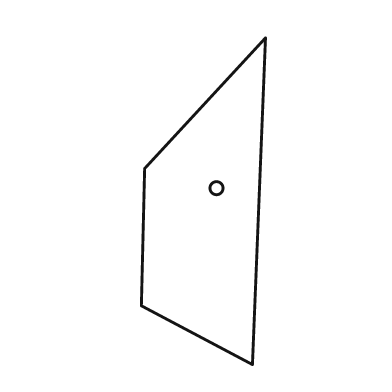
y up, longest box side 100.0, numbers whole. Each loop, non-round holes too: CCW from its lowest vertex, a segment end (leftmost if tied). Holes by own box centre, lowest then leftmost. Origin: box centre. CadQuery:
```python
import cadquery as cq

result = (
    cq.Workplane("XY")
    .moveTo(15.0, -50.0)
    .lineTo(19.0, 50.0)
    .lineTo(-18.0, 10.0)
    .lineTo(-19.0, -32.0)
    .close()
    .moveTo(4.0, 4.0)
    .circle(2.0)
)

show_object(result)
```